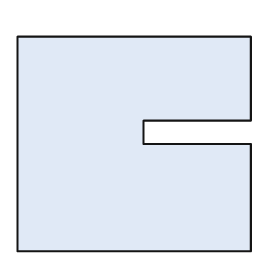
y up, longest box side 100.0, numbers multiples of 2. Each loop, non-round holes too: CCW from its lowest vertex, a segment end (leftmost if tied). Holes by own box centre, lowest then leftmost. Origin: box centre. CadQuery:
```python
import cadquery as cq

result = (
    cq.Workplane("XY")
    .moveTo(-50.0, -46.0)
    .lineTo(50.0, -46.0)
    .lineTo(50.0, 0.0)
    .lineTo(4.0, 0.0)
    .lineTo(4.0, 10.0)
    .lineTo(50.0, 10.0)
    .lineTo(50.0, 46.0)
    .lineTo(-50.0, 46.0)
    .close()
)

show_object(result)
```